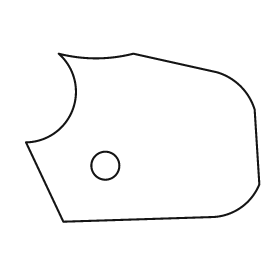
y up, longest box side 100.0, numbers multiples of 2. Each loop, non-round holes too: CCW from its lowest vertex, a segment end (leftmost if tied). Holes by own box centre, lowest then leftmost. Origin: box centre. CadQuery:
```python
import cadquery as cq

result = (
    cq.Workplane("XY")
    .moveTo(-34.0, -36.0)
    .lineTo(30.0, -34.0)
    .threePointArc((42.0, -30.0), (50.0, -20.0))
    .lineTo(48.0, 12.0)
    .threePointArc((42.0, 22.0), (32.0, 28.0))
    .lineTo(-4.0, 36.0)
    .threePointArc((-20.0, 34.0), (-36.0, 36.0))
    .threePointArc((-30.0, 12.0), (-50.0, -2.0))
    .close()
    .moveTo(-16.0, -12.0)
    .circle(6.0)
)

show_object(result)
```